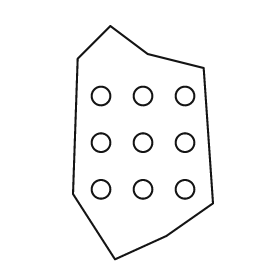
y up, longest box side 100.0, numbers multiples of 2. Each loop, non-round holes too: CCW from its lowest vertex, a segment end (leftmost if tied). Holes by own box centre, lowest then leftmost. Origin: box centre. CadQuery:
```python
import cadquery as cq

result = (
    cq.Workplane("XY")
    .moveTo(-12.0, -50.0)
    .lineTo(10.0, -40.0)
    .lineTo(30.0, -26.0)
    .lineTo(26.0, 32.0)
    .lineTo(2.0, 38.0)
    .lineTo(-14.0, 50.0)
    .lineTo(-28.0, 36.0)
    .lineTo(-30.0, -22.0)
    .close()
    .moveTo(-18.0, -20.0)
    .circle(4.0)
    .moveTo(0.0, -20.0)
    .circle(4.0)
    .moveTo(18.0, -20.0)
    .circle(4.0)
    .moveTo(-18.0, 0.0)
    .circle(4.0)
    .moveTo(0.0, 0.0)
    .circle(4.0)
    .moveTo(18.0, 0.0)
    .circle(4.0)
    .moveTo(-18.0, 20.0)
    .circle(4.0)
    .moveTo(0.0, 20.0)
    .circle(4.0)
    .moveTo(18.0, 20.0)
    .circle(4.0)
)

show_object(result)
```